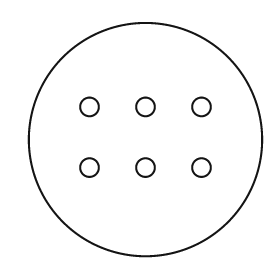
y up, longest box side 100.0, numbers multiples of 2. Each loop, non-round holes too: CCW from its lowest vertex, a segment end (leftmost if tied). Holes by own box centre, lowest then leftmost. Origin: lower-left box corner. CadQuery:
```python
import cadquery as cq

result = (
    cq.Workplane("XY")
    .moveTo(50.0, 50.0)
    .circle(50.0)
    .moveTo(26.0, 38.0)
    .circle(4.0)
    .moveTo(50.0, 38.0)
    .circle(4.0)
    .moveTo(74.0, 38.0)
    .circle(4.0)
    .moveTo(26.0, 64.0)
    .circle(4.0)
    .moveTo(50.0, 64.0)
    .circle(4.0)
    .moveTo(74.0, 64.0)
    .circle(4.0)
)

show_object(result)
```